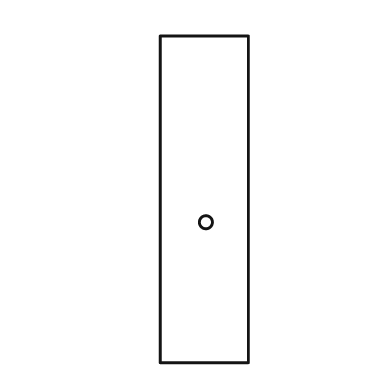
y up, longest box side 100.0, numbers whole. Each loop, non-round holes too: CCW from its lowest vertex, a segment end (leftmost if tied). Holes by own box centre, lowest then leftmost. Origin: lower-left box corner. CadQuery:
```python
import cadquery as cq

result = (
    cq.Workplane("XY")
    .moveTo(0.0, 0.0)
    .lineTo(27.0, 0.0)
    .lineTo(27.0, 100.0)
    .lineTo(0.0, 100.0)
    .close()
    .moveTo(14.0, 43.0)
    .circle(2.0)
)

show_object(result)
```